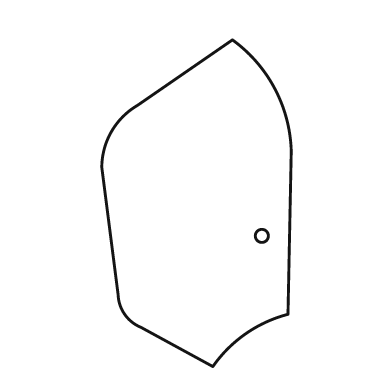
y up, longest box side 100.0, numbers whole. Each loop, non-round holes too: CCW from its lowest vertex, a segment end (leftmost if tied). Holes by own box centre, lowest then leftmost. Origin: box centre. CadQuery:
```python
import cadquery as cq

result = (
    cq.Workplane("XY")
    .moveTo(5.0, -50.0)
    .threePointArc((15.0, -40.0), (28.0, -34.0))
    .lineTo(29.0, 16.0)
    .threePointArc((24.0, 35.0), (11.0, 50.0))
    .lineTo(-18.0, 30.0)
    .threePointArc((-26.0, 22.0), (-29.0, 11.0))
    .lineTo(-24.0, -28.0)
    .threePointArc((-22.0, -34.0), (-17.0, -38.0))
    .close()
    .moveTo(20.0, -10.0)
    .circle(2.0)
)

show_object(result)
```